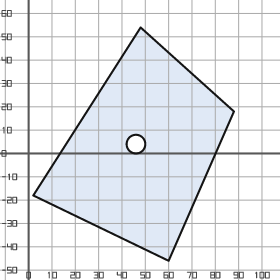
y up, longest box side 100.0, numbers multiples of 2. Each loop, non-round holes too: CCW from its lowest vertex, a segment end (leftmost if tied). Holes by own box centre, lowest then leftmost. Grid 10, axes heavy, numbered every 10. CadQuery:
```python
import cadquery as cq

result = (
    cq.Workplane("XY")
    .moveTo(60.0, -46.0)
    .lineTo(88.0, 18.0)
    .lineTo(48.0, 54.0)
    .lineTo(2.0, -18.0)
    .close()
    .moveTo(46.0, 4.0)
    .circle(4.0)
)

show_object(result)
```